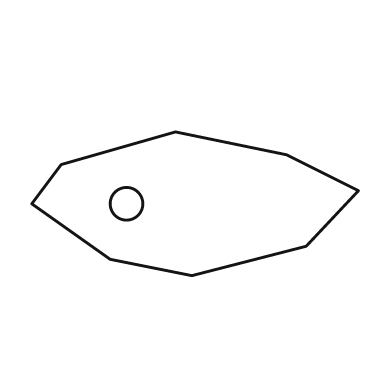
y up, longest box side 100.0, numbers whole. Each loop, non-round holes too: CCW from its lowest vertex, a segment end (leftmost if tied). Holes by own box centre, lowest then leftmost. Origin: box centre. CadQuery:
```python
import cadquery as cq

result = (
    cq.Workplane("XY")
    .moveTo(-1.0, -22.0)
    .lineTo(34.0, -13.0)
    .lineTo(50.0, 4.0)
    .lineTo(28.0, 15.0)
    .lineTo(-6.0, 22.0)
    .lineTo(-41.0, 12.0)
    .lineTo(-50.0, 0.0)
    .lineTo(-26.0, -17.0)
    .close()
    .moveTo(-21.0, 0.0)
    .circle(5.0)
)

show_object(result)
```